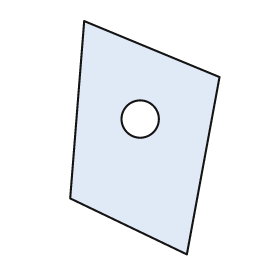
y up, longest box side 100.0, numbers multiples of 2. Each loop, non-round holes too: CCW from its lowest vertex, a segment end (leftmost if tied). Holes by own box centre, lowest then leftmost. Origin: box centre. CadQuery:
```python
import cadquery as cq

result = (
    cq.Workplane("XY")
    .moveTo(18.0, -50.0)
    .lineTo(32.0, 26.0)
    .lineTo(-26.0, 50.0)
    .lineTo(-32.0, -26.0)
    .close()
    .moveTo(-2.0, 8.0)
    .circle(8.0)
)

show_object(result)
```